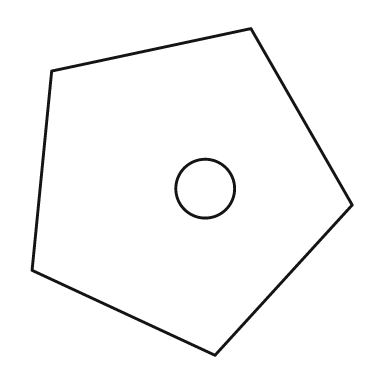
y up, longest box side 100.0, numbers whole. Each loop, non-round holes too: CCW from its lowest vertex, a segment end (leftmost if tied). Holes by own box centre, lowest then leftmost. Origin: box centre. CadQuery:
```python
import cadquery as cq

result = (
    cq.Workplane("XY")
    .moveTo(7.0, -50.0)
    .lineTo(49.0, -4.0)
    .lineTo(18.0, 50.0)
    .lineTo(-43.0, 37.0)
    .lineTo(-49.0, -24.0)
    .close()
    .moveTo(4.0, 1.0)
    .circle(9.0)
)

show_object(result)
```